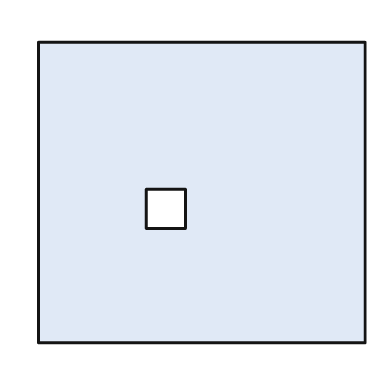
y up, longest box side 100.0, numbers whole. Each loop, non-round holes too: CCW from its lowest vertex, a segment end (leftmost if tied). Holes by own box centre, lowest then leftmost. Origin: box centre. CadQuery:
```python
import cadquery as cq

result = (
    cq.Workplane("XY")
    .moveTo(-50.0, -46.0)
    .lineTo(50.0, -46.0)
    .lineTo(50.0, 46.0)
    .lineTo(-50.0, 46.0)
    .close()
    .moveTo(-17.0, -11.0)
    .lineTo(-5.0, -11.0)
    .lineTo(-5.0, 1.0)
    .lineTo(-17.0, 1.0)
    .close()
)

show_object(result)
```